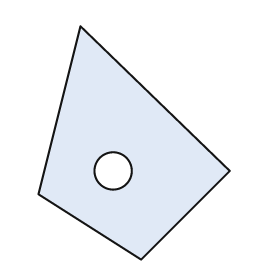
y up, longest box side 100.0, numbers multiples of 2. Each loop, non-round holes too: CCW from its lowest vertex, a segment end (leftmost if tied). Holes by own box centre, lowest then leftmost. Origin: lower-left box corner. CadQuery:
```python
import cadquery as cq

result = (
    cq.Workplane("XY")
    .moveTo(44.0, 0.0)
    .lineTo(82.0, 38.0)
    .lineTo(18.0, 100.0)
    .lineTo(0.0, 28.0)
    .close()
    .moveTo(32.0, 38.0)
    .circle(8.0)
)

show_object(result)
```